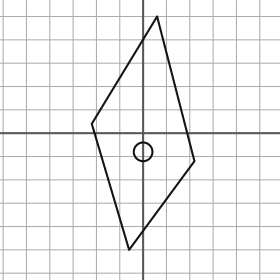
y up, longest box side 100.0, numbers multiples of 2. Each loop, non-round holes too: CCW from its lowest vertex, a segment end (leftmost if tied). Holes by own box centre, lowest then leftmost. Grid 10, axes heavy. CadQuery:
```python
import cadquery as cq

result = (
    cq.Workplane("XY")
    .moveTo(-6.0, -50.0)
    .lineTo(22.0, -12.0)
    .lineTo(6.0, 50.0)
    .lineTo(-22.0, 4.0)
    .close()
    .moveTo(0.0, -8.0)
    .circle(4.0)
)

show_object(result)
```